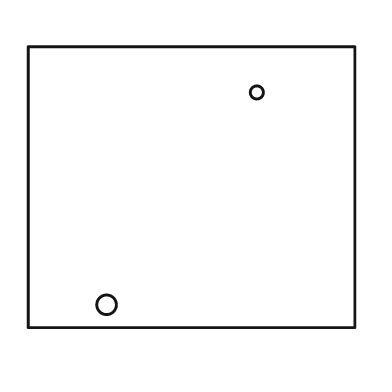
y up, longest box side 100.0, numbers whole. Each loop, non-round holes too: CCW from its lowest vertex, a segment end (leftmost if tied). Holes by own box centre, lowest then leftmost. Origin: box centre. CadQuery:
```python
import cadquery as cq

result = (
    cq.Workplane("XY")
    .moveTo(-50.0, -43.0)
    .lineTo(50.0, -43.0)
    .lineTo(50.0, 43.0)
    .lineTo(-50.0, 43.0)
    .close()
    .moveTo(-26.0, -36.0)
    .circle(3.0)
    .moveTo(20.0, 29.0)
    .circle(2.0)
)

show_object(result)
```